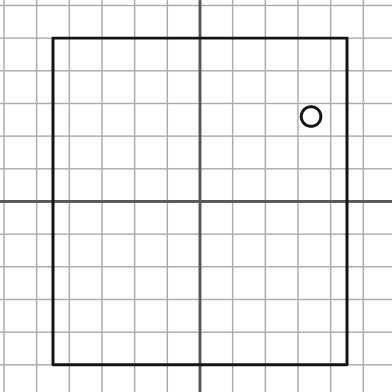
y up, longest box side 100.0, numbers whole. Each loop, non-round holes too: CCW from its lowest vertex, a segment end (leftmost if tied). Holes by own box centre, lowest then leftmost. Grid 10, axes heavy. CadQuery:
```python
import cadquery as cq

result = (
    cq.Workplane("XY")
    .moveTo(-45.0, -50.0)
    .lineTo(45.0, -50.0)
    .lineTo(45.0, 50.0)
    .lineTo(-45.0, 50.0)
    .close()
    .moveTo(34.0, 26.0)
    .circle(3.0)
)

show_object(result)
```